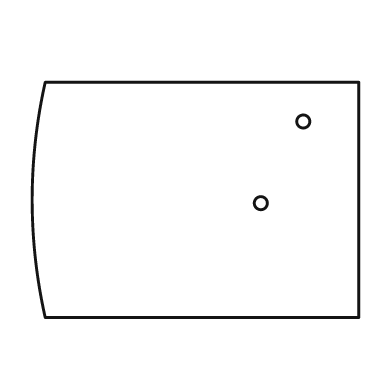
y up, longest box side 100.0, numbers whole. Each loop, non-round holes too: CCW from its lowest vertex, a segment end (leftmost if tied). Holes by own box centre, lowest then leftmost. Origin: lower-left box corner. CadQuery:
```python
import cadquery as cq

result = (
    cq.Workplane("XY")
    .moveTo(4.0, 0.0)
    .lineTo(100.0, 0.0)
    .lineTo(100.0, 72.0)
    .lineTo(4.0, 72.0)
    .threePointArc((0.0, 36.0), (4.0, 0.0))
    .close()
    .moveTo(70.0, 35.0)
    .circle(2.0)
    .moveTo(83.0, 60.0)
    .circle(2.0)
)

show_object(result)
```